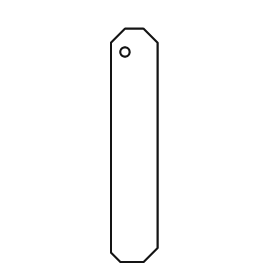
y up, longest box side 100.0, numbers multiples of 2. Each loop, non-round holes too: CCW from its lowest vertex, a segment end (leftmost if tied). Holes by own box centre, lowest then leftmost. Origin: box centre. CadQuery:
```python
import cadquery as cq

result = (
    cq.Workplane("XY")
    .moveTo(-6.0, -50.0)
    .lineTo(4.0, -50.0)
    .lineTo(10.0, -44.0)
    .lineTo(10.0, 44.0)
    .lineTo(4.0, 50.0)
    .lineTo(-4.0, 50.0)
    .lineTo(-10.0, 44.0)
    .lineTo(-10.0, -46.0)
    .close()
    .moveTo(-4.0, 40.0)
    .circle(2.0)
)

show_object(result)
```